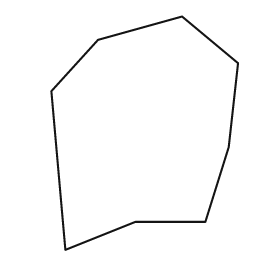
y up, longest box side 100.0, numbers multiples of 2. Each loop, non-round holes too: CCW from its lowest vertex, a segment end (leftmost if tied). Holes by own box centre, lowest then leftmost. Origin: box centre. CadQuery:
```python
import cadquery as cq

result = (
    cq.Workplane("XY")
    .moveTo(-34.0, -50.0)
    .lineTo(-4.0, -38.0)
    .lineTo(26.0, -38.0)
    .lineTo(36.0, -6.0)
    .lineTo(40.0, 30.0)
    .lineTo(16.0, 50.0)
    .lineTo(-20.0, 40.0)
    .lineTo(-40.0, 18.0)
    .close()
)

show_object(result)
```